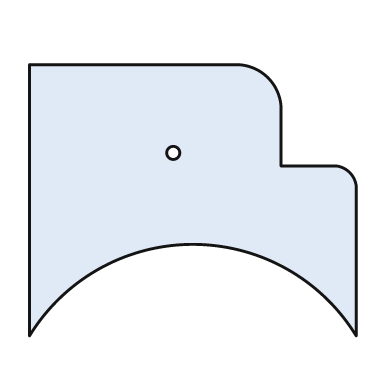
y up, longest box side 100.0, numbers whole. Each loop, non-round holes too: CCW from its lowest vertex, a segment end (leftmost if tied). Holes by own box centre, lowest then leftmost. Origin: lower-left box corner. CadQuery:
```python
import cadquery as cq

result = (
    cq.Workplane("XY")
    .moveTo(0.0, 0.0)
    .threePointArc((50.0, 28.0), (100.0, 0.0))
    .lineTo(100.0, 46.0)
    .threePointArc((98.0, 50.0), (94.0, 52.0))
    .lineTo(77.0, 52.0)
    .lineTo(77.0, 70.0)
    .threePointArc((73.0, 79.0), (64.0, 83.0))
    .lineTo(0.0, 83.0)
    .close()
    .moveTo(44.0, 56.0)
    .circle(2.0)
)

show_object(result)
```